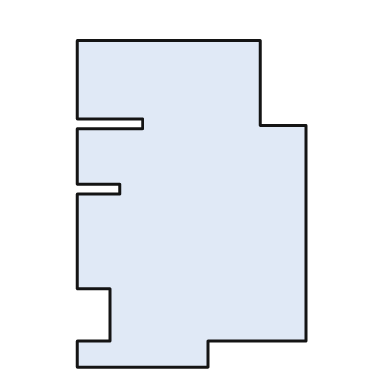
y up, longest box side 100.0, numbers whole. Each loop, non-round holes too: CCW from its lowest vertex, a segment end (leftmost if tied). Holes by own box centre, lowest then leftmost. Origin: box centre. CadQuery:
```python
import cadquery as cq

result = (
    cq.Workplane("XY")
    .moveTo(-35.0, -50.0)
    .lineTo(5.0, -50.0)
    .lineTo(5.0, -42.0)
    .lineTo(35.0, -42.0)
    .lineTo(35.0, 24.0)
    .lineTo(21.0, 24.0)
    .lineTo(21.0, 50.0)
    .lineTo(-35.0, 50.0)
    .lineTo(-35.0, 26.0)
    .lineTo(-15.0, 26.0)
    .lineTo(-15.0, 23.0)
    .lineTo(-35.0, 23.0)
    .lineTo(-35.0, 6.0)
    .lineTo(-22.0, 6.0)
    .lineTo(-22.0, 3.0)
    .lineTo(-35.0, 3.0)
    .lineTo(-35.0, -26.0)
    .lineTo(-25.0, -26.0)
    .lineTo(-25.0, -42.0)
    .lineTo(-35.0, -42.0)
    .close()
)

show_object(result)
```